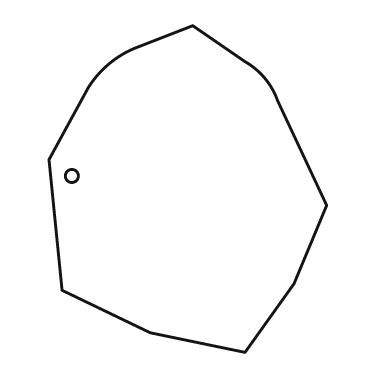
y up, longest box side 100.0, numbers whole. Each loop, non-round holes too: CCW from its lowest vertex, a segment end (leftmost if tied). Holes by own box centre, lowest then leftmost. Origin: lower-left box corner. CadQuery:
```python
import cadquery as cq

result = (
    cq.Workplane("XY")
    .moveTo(60.0, 0.0)
    .lineTo(75.0, 21.0)
    .lineTo(85.0, 45.0)
    .lineTo(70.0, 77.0)
    .threePointArc((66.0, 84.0), (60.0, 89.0))
    .lineTo(44.0, 100.0)
    .lineTo(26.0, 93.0)
    .threePointArc((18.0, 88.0), (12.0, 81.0))
    .lineTo(0.0, 59.0)
    .lineTo(4.0, 19.0)
    .lineTo(31.0, 6.0)
    .close()
    .moveTo(7.0, 54.0)
    .circle(2.0)
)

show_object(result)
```